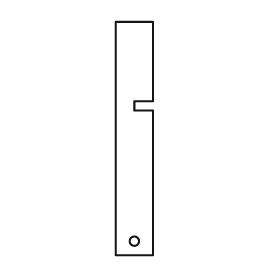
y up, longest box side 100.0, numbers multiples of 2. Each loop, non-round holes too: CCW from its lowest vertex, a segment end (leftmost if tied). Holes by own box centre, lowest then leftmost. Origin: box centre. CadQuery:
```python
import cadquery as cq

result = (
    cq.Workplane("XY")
    .moveTo(-8.0, -50.0)
    .lineTo(8.0, -50.0)
    .lineTo(8.0, 12.0)
    .lineTo(0.0, 12.0)
    .lineTo(0.0, 16.0)
    .lineTo(8.0, 16.0)
    .lineTo(8.0, 50.0)
    .lineTo(-8.0, 50.0)
    .close()
    .moveTo(0.0, -44.0)
    .circle(2.0)
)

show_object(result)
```